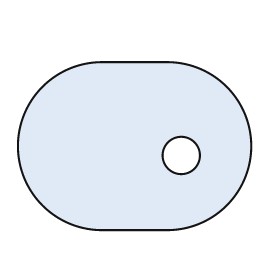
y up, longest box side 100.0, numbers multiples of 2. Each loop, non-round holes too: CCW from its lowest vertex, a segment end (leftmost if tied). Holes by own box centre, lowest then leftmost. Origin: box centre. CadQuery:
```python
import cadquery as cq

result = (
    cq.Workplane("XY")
    .moveTo(-14.0, -36.0)
    .lineTo(14.0, -36.0)
    .threePointArc((50.0, 0.0), (14.0, 36.0))
    .lineTo(-14.0, 36.0)
    .threePointArc((-50.0, 0.0), (-14.0, -36.0))
    .close()
    .moveTo(20.0, -4.0)
    .circle(8.0)
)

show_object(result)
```